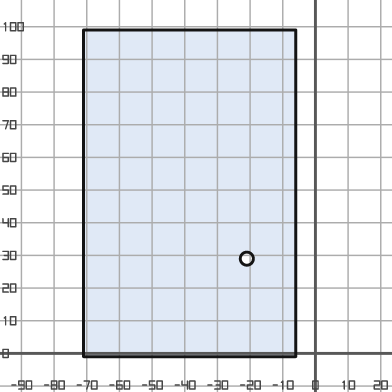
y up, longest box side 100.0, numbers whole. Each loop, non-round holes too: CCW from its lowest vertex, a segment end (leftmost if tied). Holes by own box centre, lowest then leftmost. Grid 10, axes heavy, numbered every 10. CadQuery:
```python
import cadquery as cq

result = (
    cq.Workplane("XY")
    .moveTo(-71.0, -1.0)
    .lineTo(-6.0, -1.0)
    .lineTo(-6.0, 99.0)
    .lineTo(-71.0, 99.0)
    .close()
    .moveTo(-21.0, 29.0)
    .circle(2.0)
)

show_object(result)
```